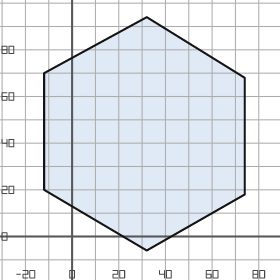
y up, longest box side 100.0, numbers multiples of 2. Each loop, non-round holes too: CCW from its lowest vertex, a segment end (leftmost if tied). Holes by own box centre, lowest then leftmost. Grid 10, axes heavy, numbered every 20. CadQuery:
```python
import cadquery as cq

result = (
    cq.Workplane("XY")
    .moveTo(32.0, -6.0)
    .lineTo(74.0, 18.0)
    .lineTo(74.0, 68.0)
    .lineTo(32.0, 94.0)
    .lineTo(-12.0, 70.0)
    .lineTo(-12.0, 20.0)
    .close()
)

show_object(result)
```